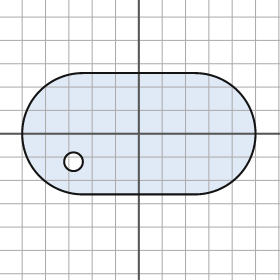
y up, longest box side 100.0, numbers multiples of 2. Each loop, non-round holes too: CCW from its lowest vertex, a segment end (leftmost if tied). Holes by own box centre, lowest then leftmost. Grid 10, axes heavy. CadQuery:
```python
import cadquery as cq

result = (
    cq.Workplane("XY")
    .moveTo(-24.0, -26.0)
    .lineTo(24.0, -26.0)
    .threePointArc((50.0, 0.0), (24.0, 26.0))
    .lineTo(-24.0, 26.0)
    .threePointArc((-50.0, 0.0), (-24.0, -26.0))
    .close()
    .moveTo(-28.0, -12.0)
    .circle(4.0)
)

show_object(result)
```